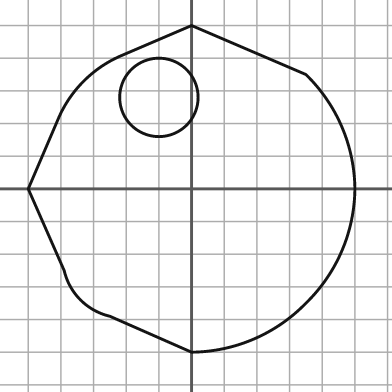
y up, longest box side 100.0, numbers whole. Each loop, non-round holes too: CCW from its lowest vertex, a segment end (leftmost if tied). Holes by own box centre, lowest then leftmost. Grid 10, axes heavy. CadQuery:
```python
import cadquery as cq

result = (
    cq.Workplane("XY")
    .moveTo(0.0, -50.0)
    .threePointArc((19.0, -46.0), (35.0, -35.0))
    .threePointArc((46.0, -19.0), (50.0, 0.0))
    .threePointArc((46.0, 19.0), (35.0, 35.0))
    .lineTo(0.0, 50.0)
    .lineTo(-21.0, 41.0)
    .threePointArc((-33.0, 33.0), (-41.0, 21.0))
    .lineTo(-50.0, 0.0)
    .lineTo(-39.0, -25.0)
    .threePointArc((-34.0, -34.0), (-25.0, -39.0))
    .close()
    .moveTo(-10.0, 28.0)
    .circle(12.0)
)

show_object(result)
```